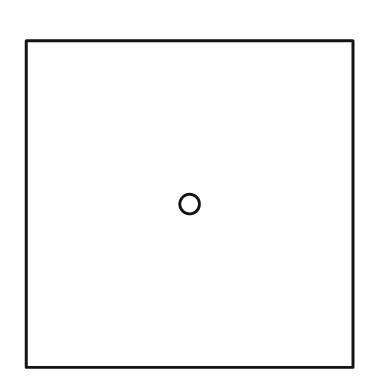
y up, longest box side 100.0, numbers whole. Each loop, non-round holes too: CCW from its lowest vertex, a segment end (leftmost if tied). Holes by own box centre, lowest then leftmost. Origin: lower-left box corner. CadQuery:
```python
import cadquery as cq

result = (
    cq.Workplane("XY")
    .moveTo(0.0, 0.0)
    .lineTo(100.0, 0.0)
    .lineTo(100.0, 100.0)
    .lineTo(0.0, 100.0)
    .close()
    .moveTo(50.0, 50.0)
    .circle(3.0)
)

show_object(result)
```